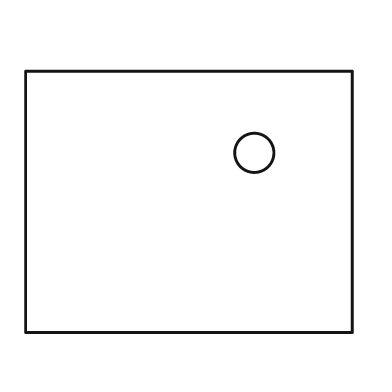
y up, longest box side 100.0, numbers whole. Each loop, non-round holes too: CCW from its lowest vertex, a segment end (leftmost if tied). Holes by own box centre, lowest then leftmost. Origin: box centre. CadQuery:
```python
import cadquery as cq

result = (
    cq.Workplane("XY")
    .moveTo(-50.0, -40.0)
    .lineTo(50.0, -40.0)
    .lineTo(50.0, 40.0)
    .lineTo(-50.0, 40.0)
    .close()
    .moveTo(20.0, 15.0)
    .circle(6.0)
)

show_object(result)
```